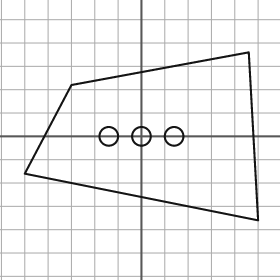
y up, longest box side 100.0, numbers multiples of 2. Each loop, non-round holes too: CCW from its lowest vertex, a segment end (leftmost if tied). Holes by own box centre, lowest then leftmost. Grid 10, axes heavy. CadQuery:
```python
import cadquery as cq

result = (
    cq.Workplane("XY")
    .moveTo(50.0, -36.0)
    .lineTo(46.0, 36.0)
    .lineTo(-30.0, 22.0)
    .lineTo(-50.0, -16.0)
    .close()
    .moveTo(-14.0, 0.0)
    .circle(4.0)
    .moveTo(0.0, 0.0)
    .circle(4.0)
    .moveTo(14.0, 0.0)
    .circle(4.0)
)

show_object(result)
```